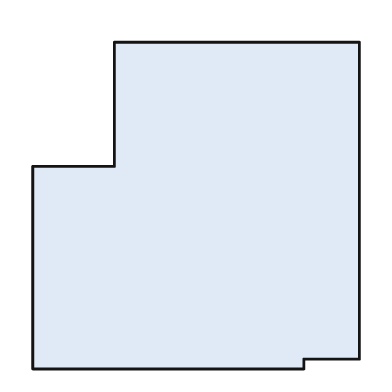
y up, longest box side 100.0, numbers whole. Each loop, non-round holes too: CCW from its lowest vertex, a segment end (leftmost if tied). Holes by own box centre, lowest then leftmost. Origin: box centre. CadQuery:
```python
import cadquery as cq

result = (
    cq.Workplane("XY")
    .moveTo(-50.0, -50.0)
    .lineTo(33.0, -50.0)
    .lineTo(33.0, -47.0)
    .lineTo(50.0, -47.0)
    .lineTo(50.0, 50.0)
    .lineTo(-25.0, 50.0)
    .lineTo(-25.0, 12.0)
    .lineTo(-50.0, 12.0)
    .close()
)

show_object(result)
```